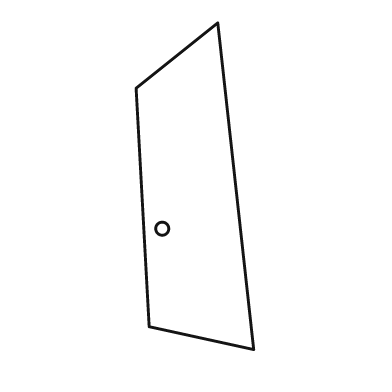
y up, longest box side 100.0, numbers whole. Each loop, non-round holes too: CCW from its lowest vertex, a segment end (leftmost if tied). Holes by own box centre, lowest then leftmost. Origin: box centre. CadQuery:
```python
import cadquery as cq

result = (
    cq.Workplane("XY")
    .moveTo(18.0, -50.0)
    .lineTo(7.0, 50.0)
    .lineTo(-18.0, 30.0)
    .lineTo(-14.0, -43.0)
    .close()
    .moveTo(-10.0, -13.0)
    .circle(2.0)
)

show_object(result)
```